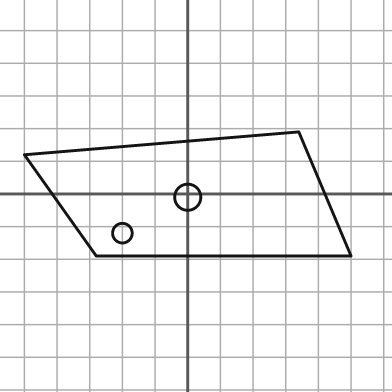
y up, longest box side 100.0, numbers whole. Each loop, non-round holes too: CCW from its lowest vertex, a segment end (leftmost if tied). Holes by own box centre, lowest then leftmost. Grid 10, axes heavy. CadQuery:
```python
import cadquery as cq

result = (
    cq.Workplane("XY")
    .moveTo(-28.0, -19.0)
    .lineTo(50.0, -19.0)
    .lineTo(34.0, 19.0)
    .lineTo(-50.0, 12.0)
    .close()
    .moveTo(-20.0, -12.0)
    .circle(3.0)
    .moveTo(0.0, -1.0)
    .circle(4.0)
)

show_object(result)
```